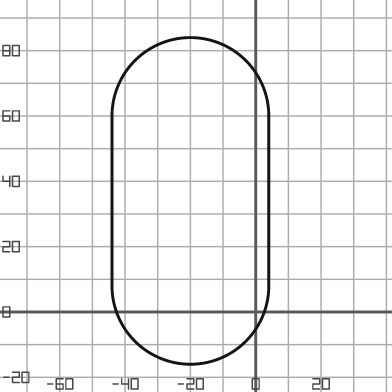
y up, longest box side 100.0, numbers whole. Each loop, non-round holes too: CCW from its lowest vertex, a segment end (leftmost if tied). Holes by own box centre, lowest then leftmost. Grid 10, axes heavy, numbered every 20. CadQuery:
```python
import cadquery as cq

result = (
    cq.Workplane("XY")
    .moveTo(-44.0, 8.0)
    .threePointArc((-20.0, -16.0), (4.0, 8.0))
    .lineTo(4.0, 60.0)
    .threePointArc((-20.0, 84.0), (-44.0, 60.0))
    .close()
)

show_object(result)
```